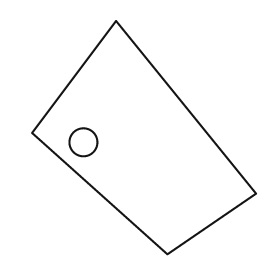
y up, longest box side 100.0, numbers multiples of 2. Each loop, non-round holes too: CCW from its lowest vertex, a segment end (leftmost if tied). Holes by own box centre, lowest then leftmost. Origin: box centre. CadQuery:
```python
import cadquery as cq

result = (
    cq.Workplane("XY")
    .moveTo(10.0, -50.0)
    .lineTo(48.0, -24.0)
    .lineTo(-12.0, 50.0)
    .lineTo(-48.0, 2.0)
    .close()
    .moveTo(-26.0, -2.0)
    .circle(6.0)
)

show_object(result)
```